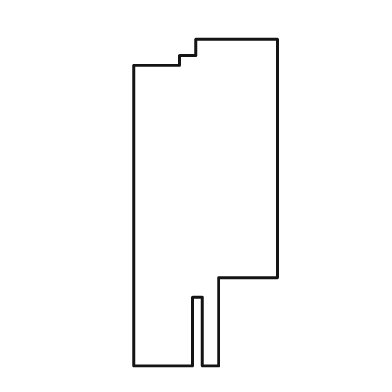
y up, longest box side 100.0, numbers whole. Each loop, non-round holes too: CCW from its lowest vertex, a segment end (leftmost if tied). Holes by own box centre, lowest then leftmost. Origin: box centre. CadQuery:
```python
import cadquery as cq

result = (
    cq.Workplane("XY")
    .moveTo(-22.0, -50.0)
    .lineTo(-4.0, -50.0)
    .lineTo(-4.0, -29.0)
    .lineTo(-1.0, -29.0)
    .lineTo(-1.0, -50.0)
    .lineTo(4.0, -50.0)
    .lineTo(4.0, -23.0)
    .lineTo(22.0, -23.0)
    .lineTo(22.0, 50.0)
    .lineTo(-3.0, 50.0)
    .lineTo(-3.0, 45.0)
    .lineTo(-8.0, 45.0)
    .lineTo(-8.0, 42.0)
    .lineTo(-22.0, 42.0)
    .close()
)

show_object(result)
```